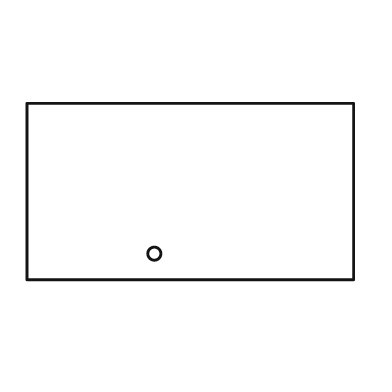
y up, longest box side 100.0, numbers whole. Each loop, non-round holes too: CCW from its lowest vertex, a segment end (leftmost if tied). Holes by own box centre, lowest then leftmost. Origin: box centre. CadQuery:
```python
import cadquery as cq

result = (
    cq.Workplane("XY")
    .moveTo(-50.0, -27.0)
    .lineTo(50.0, -27.0)
    .lineTo(50.0, 27.0)
    .lineTo(-50.0, 27.0)
    .close()
    .moveTo(-11.0, -19.0)
    .circle(2.0)
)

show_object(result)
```